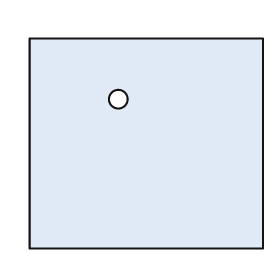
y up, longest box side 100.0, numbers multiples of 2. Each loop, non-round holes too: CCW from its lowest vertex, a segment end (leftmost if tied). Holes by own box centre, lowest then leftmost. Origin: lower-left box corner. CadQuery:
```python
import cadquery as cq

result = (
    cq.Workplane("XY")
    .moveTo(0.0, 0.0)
    .lineTo(100.0, 0.0)
    .lineTo(100.0, 90.0)
    .lineTo(0.0, 90.0)
    .close()
    .moveTo(38.0, 64.0)
    .circle(4.0)
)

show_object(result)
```